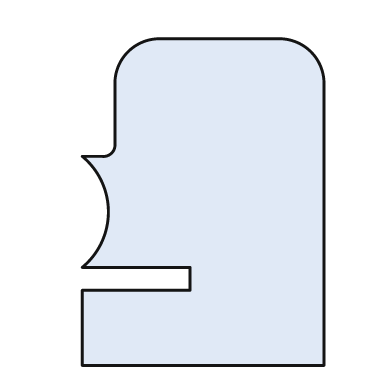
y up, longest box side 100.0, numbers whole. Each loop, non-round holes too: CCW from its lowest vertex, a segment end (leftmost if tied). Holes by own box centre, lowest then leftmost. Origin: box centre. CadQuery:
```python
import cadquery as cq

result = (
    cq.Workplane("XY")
    .moveTo(-37.0, -50.0)
    .lineTo(37.0, -50.0)
    .lineTo(37.0, 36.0)
    .threePointArc((33.0, 46.0), (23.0, 50.0))
    .lineTo(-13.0, 50.0)
    .threePointArc((-23.0, 46.0), (-27.0, 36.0))
    .lineTo(-27.0, 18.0)
    .threePointArc((-28.0, 15.0), (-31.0, 14.0))
    .lineTo(-37.0, 14.0)
    .threePointArc((-29.0, -3.0), (-37.0, -20.0))
    .lineTo(-4.0, -20.0)
    .lineTo(-4.0, -27.0)
    .lineTo(-37.0, -27.0)
    .close()
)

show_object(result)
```